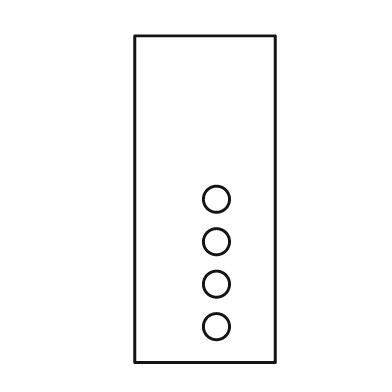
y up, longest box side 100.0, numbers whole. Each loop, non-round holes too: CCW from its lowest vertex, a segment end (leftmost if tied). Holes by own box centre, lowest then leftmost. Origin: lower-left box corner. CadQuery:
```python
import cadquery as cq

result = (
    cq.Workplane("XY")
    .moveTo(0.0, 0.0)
    .lineTo(43.0, 0.0)
    .lineTo(43.0, 100.0)
    .lineTo(0.0, 100.0)
    .close()
    .moveTo(25.0, 11.0)
    .circle(4.0)
    .moveTo(25.0, 24.0)
    .circle(4.0)
    .moveTo(25.0, 37.0)
    .circle(4.0)
    .moveTo(25.0, 50.0)
    .circle(4.0)
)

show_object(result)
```